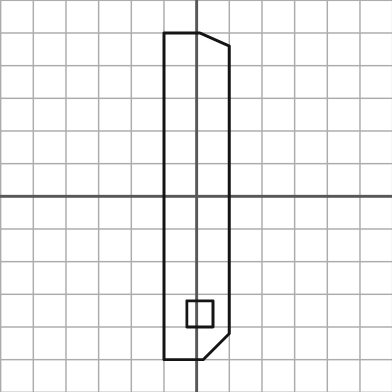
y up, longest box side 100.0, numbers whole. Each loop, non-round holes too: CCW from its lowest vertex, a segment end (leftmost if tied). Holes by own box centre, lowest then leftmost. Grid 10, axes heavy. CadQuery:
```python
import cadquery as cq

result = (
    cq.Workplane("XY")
    .moveTo(-10.0, -50.0)
    .lineTo(2.0, -50.0)
    .lineTo(10.0, -42.0)
    .lineTo(10.0, 46.0)
    .lineTo(1.0, 50.0)
    .lineTo(-10.0, 50.0)
    .close()
    .moveTo(-3.0, -40.0)
    .lineTo(5.0, -40.0)
    .lineTo(5.0, -32.0)
    .lineTo(-3.0, -32.0)
    .close()
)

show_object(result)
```